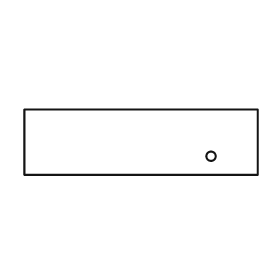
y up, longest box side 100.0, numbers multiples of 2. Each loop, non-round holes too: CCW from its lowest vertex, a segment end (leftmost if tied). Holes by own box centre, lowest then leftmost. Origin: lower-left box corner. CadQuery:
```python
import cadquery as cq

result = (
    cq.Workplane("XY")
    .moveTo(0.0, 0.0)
    .lineTo(100.0, 0.0)
    .lineTo(100.0, 28.0)
    .lineTo(0.0, 28.0)
    .close()
    .moveTo(80.0, 8.0)
    .circle(2.0)
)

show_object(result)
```